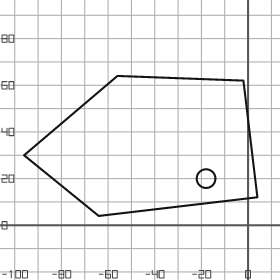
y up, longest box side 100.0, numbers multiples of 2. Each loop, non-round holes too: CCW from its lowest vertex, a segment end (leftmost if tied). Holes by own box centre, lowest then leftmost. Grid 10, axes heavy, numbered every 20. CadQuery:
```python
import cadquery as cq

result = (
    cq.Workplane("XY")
    .moveTo(-64.0, 4.0)
    .lineTo(4.0, 12.0)
    .lineTo(-2.0, 62.0)
    .lineTo(-56.0, 64.0)
    .lineTo(-96.0, 30.0)
    .close()
    .moveTo(-18.0, 20.0)
    .circle(4.0)
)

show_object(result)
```